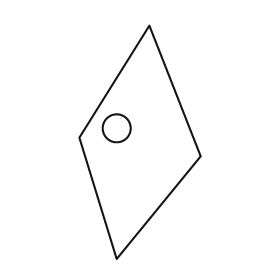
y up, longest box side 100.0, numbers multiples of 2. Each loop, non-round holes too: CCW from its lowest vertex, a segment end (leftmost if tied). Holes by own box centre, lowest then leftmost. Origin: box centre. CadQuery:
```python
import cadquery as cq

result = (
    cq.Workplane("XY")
    .moveTo(-10.0, -50.0)
    .lineTo(26.0, -6.0)
    .lineTo(4.0, 50.0)
    .lineTo(-26.0, 2.0)
    .close()
    .moveTo(-10.0, 6.0)
    .circle(6.0)
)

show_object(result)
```